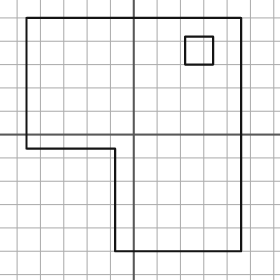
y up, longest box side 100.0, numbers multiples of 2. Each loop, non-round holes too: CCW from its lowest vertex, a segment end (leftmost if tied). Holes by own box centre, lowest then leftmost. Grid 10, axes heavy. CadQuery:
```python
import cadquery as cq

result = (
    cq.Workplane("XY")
    .moveTo(-8.0, -50.0)
    .lineTo(46.0, -50.0)
    .lineTo(46.0, 50.0)
    .lineTo(-46.0, 50.0)
    .lineTo(-46.0, -6.0)
    .lineTo(-8.0, -6.0)
    .close()
    .moveTo(22.0, 30.0)
    .lineTo(34.0, 30.0)
    .lineTo(34.0, 42.0)
    .lineTo(22.0, 42.0)
    .close()
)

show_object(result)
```